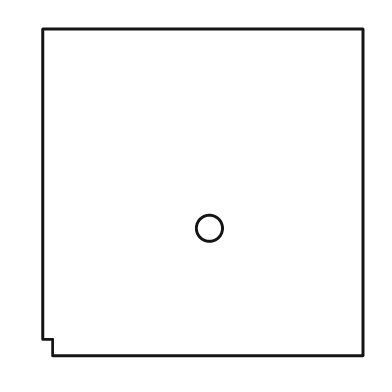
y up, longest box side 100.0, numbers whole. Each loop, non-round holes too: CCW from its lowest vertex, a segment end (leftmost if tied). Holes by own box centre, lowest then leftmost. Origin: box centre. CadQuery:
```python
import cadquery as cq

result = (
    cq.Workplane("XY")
    .moveTo(-46.0, -50.0)
    .lineTo(49.0, -50.0)
    .lineTo(49.0, 50.0)
    .lineTo(-49.0, 50.0)
    .lineTo(-49.0, -45.0)
    .lineTo(-46.0, -45.0)
    .close()
    .moveTo(2.0, -11.0)
    .circle(4.0)
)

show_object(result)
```